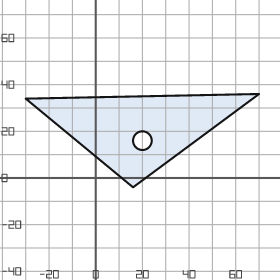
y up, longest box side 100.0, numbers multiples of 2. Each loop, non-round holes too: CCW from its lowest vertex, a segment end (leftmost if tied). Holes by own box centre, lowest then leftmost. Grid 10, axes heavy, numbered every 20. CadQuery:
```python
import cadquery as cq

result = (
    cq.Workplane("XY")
    .moveTo(16.0, -4.0)
    .lineTo(70.0, 36.0)
    .lineTo(-30.0, 34.0)
    .close()
    .moveTo(20.0, 16.0)
    .circle(4.0)
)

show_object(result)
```